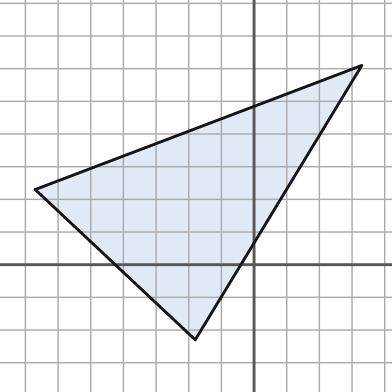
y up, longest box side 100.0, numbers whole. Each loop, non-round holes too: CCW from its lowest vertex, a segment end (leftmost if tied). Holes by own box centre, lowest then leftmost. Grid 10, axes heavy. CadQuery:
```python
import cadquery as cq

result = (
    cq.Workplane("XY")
    .moveTo(-18.0, -23.0)
    .lineTo(33.0, 61.0)
    .lineTo(-67.0, 23.0)
    .close()
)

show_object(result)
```